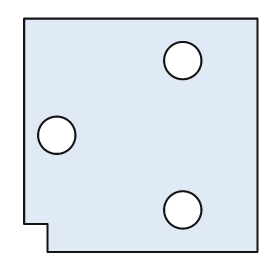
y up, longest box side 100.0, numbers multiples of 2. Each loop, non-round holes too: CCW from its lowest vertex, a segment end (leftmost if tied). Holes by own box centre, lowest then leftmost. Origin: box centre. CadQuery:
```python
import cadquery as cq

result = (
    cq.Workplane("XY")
    .moveTo(-40.0, -50.0)
    .lineTo(50.0, -50.0)
    .lineTo(50.0, 50.0)
    .lineTo(-50.0, 50.0)
    .lineTo(-50.0, -38.0)
    .lineTo(-40.0, -38.0)
    .close()
    .moveTo(18.0, -32.0)
    .circle(8.0)
    .moveTo(-36.0, 0.0)
    .circle(8.0)
    .moveTo(18.0, 32.0)
    .circle(8.0)
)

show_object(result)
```